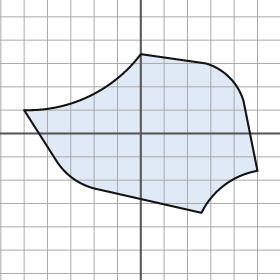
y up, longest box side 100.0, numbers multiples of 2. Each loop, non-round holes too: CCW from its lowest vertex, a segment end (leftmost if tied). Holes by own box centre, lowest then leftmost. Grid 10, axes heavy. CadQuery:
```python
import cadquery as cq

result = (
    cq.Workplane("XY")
    .moveTo(26.0, -34.0)
    .threePointArc((36.0, -22.0), (50.0, -16.0))
    .lineTo(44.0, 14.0)
    .threePointArc((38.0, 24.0), (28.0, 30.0))
    .lineTo(0.0, 34.0)
    .threePointArc((-22.0, 16.0), (-50.0, 10.0))
    .lineTo(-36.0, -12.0)
    .threePointArc((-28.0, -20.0), (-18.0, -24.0))
    .close()
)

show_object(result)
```